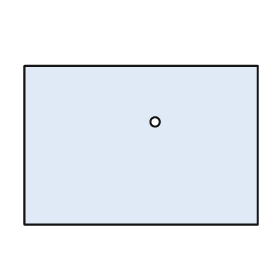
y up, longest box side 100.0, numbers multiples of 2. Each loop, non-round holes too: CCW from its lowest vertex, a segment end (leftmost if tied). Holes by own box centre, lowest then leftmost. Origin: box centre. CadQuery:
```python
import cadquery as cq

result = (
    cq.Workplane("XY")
    .moveTo(-50.0, -34.0)
    .lineTo(50.0, -34.0)
    .lineTo(50.0, 34.0)
    .lineTo(-50.0, 34.0)
    .close()
    .moveTo(6.0, 10.0)
    .circle(2.0)
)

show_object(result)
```